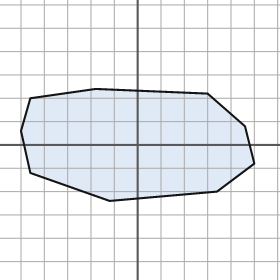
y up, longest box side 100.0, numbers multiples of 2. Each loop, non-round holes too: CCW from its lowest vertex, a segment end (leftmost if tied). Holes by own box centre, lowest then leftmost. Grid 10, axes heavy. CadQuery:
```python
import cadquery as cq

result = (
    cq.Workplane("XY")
    .moveTo(-12.0, -24.0)
    .lineTo(34.0, -20.0)
    .lineTo(50.0, -8.0)
    .lineTo(46.0, 8.0)
    .lineTo(30.0, 22.0)
    .lineTo(-18.0, 24.0)
    .lineTo(-46.0, 20.0)
    .lineTo(-50.0, 6.0)
    .lineTo(-46.0, -12.0)
    .close()
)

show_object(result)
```